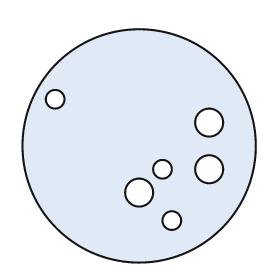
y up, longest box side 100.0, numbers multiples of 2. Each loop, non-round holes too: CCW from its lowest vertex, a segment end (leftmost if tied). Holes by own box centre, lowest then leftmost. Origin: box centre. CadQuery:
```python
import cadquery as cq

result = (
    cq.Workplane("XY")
    .moveTo(0.0, 0.0)
    .circle(50.0)
    .moveTo(14.0, -32.0)
    .circle(4.0)
    .moveTo(0.0, -20.0)
    .circle(6.0)
    .moveTo(10.0, -10.0)
    .circle(4.0)
    .moveTo(30.0, -10.0)
    .circle(6.0)
    .moveTo(30.0, 10.0)
    .circle(6.0)
    .moveTo(-36.0, 20.0)
    .circle(4.0)
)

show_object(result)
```